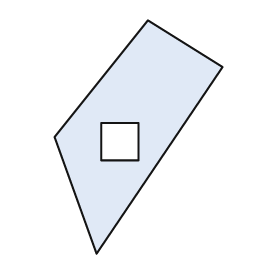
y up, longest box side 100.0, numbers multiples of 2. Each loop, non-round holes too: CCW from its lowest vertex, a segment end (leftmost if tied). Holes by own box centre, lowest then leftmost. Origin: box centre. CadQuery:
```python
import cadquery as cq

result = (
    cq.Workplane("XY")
    .moveTo(-18.0, -50.0)
    .lineTo(36.0, 30.0)
    .lineTo(4.0, 50.0)
    .lineTo(-36.0, 0.0)
    .close()
    .moveTo(-16.0, -10.0)
    .lineTo(0.0, -10.0)
    .lineTo(0.0, 6.0)
    .lineTo(-16.0, 6.0)
    .close()
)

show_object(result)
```